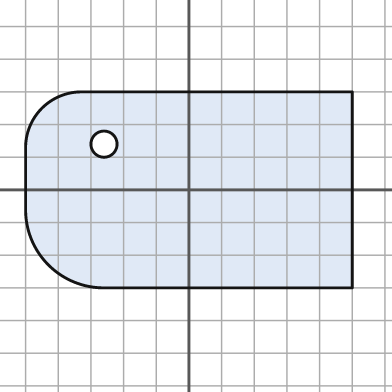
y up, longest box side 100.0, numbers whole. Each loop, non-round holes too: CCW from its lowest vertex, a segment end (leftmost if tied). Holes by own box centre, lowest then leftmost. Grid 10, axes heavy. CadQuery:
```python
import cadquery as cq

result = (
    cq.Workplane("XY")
    .moveTo(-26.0, -30.0)
    .lineTo(50.0, -30.0)
    .lineTo(50.0, 30.0)
    .lineTo(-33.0, 30.0)
    .threePointArc((-45.0, 25.0), (-50.0, 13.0))
    .lineTo(-50.0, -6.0)
    .threePointArc((-43.0, -23.0), (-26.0, -30.0))
    .close()
    .moveTo(-26.0, 14.0)
    .circle(4.0)
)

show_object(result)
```